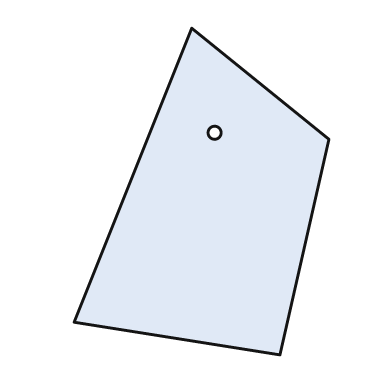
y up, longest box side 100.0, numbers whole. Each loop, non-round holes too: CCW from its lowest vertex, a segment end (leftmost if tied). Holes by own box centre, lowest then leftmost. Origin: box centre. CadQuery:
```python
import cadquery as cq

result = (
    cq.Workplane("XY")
    .moveTo(24.0, -50.0)
    .lineTo(39.0, 16.0)
    .lineTo(-3.0, 50.0)
    .lineTo(-39.0, -40.0)
    .close()
    .moveTo(4.0, 18.0)
    .circle(2.0)
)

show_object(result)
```